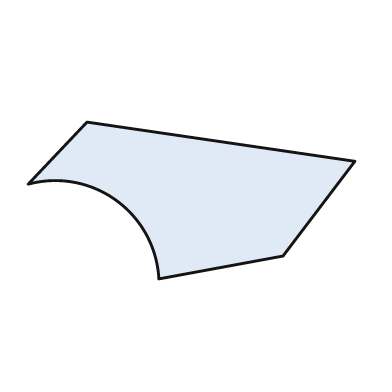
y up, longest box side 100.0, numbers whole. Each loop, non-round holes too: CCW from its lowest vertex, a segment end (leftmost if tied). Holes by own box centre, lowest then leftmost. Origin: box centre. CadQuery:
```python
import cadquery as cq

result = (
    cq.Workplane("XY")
    .moveTo(-10.0, -24.0)
    .lineTo(28.0, -17.0)
    .lineTo(50.0, 12.0)
    .lineTo(-32.0, 24.0)
    .lineTo(-50.0, 5.0)
    .threePointArc((-23.0, 0.0), (-10.0, -24.0))
    .close()
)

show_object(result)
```